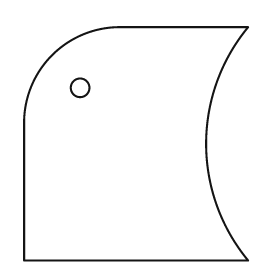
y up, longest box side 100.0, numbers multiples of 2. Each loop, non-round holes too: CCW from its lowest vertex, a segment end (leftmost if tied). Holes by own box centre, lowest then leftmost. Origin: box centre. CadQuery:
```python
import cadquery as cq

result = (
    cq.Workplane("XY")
    .moveTo(-48.0, -50.0)
    .lineTo(48.0, -50.0)
    .threePointArc((30.0, 0.0), (48.0, 50.0))
    .lineTo(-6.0, 50.0)
    .threePointArc((-36.0, 38.0), (-48.0, 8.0))
    .close()
    .moveTo(-24.0, 24.0)
    .circle(4.0)
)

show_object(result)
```